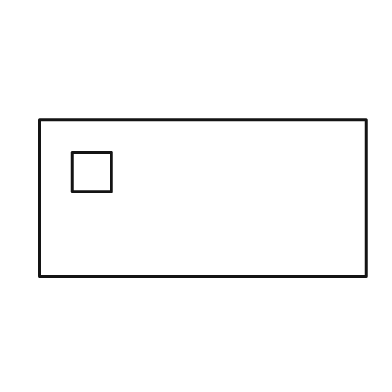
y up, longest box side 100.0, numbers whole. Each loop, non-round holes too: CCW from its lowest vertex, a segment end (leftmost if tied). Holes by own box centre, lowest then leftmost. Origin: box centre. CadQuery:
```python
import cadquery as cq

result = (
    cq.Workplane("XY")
    .moveTo(-50.0, -24.0)
    .lineTo(50.0, -24.0)
    .lineTo(50.0, 24.0)
    .lineTo(-50.0, 24.0)
    .close()
    .moveTo(-40.0, 2.0)
    .lineTo(-28.0, 2.0)
    .lineTo(-28.0, 14.0)
    .lineTo(-40.0, 14.0)
    .close()
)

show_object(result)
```